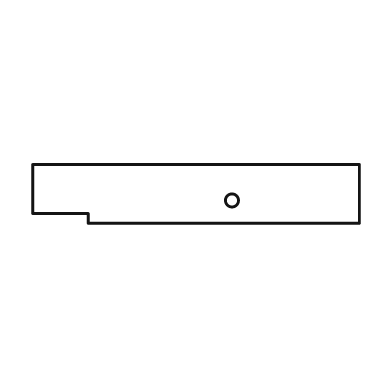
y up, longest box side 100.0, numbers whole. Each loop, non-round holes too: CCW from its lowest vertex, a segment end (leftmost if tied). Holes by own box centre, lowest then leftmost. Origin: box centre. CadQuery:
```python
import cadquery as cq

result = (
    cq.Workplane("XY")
    .moveTo(-33.0, -9.0)
    .lineTo(50.0, -9.0)
    .lineTo(50.0, 9.0)
    .lineTo(-50.0, 9.0)
    .lineTo(-50.0, -6.0)
    .lineTo(-33.0, -6.0)
    .close()
    .moveTo(11.0, -2.0)
    .circle(2.0)
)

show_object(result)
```